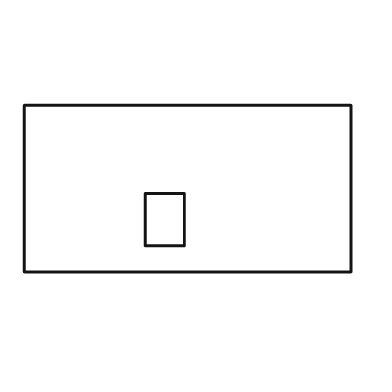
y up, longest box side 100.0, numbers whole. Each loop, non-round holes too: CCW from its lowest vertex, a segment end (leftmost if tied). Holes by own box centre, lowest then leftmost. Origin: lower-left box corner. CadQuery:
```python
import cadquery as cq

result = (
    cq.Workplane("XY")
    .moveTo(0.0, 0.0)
    .lineTo(100.0, 0.0)
    .lineTo(100.0, 51.0)
    .lineTo(0.0, 51.0)
    .close()
    .moveTo(37.0, 8.0)
    .lineTo(49.0, 8.0)
    .lineTo(49.0, 24.0)
    .lineTo(37.0, 24.0)
    .close()
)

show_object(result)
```